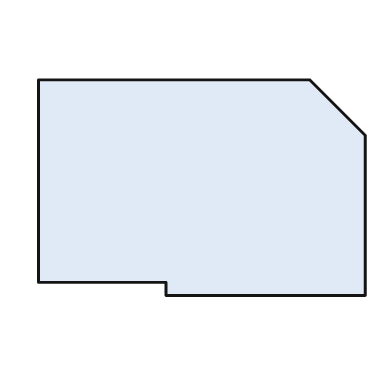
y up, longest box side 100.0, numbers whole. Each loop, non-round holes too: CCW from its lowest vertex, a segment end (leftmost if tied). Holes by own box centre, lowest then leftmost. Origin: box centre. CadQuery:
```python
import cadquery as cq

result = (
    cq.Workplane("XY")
    .moveTo(-11.0, -33.0)
    .lineTo(50.0, -33.0)
    .lineTo(50.0, 16.0)
    .lineTo(33.0, 33.0)
    .lineTo(-50.0, 33.0)
    .lineTo(-50.0, -29.0)
    .lineTo(-11.0, -29.0)
    .close()
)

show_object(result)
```